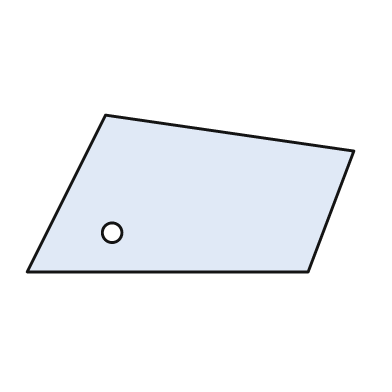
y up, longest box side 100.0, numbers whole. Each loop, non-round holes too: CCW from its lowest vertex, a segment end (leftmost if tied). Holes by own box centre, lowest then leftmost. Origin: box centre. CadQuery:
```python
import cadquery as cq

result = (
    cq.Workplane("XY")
    .moveTo(-50.0, -24.0)
    .lineTo(36.0, -24.0)
    .lineTo(50.0, 13.0)
    .lineTo(-26.0, 24.0)
    .close()
    .moveTo(-24.0, -12.0)
    .circle(3.0)
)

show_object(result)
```